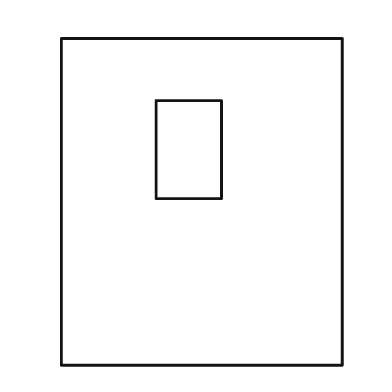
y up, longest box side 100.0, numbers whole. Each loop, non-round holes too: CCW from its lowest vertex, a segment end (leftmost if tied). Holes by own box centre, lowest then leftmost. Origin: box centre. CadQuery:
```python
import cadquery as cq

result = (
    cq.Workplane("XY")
    .moveTo(-43.0, -50.0)
    .lineTo(43.0, -50.0)
    .lineTo(43.0, 50.0)
    .lineTo(-43.0, 50.0)
    .close()
    .moveTo(-14.0, 1.0)
    .lineTo(6.0, 1.0)
    .lineTo(6.0, 31.0)
    .lineTo(-14.0, 31.0)
    .close()
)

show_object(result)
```